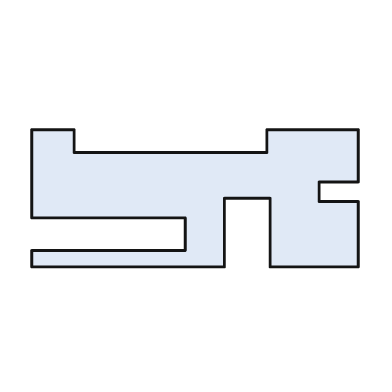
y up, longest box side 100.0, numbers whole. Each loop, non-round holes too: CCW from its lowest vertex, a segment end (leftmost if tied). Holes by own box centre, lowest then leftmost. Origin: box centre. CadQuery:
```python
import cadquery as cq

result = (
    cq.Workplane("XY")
    .moveTo(-50.0, -21.0)
    .lineTo(9.0, -21.0)
    .lineTo(9.0, 0.0)
    .lineTo(23.0, 0.0)
    .lineTo(23.0, -21.0)
    .lineTo(50.0, -21.0)
    .lineTo(50.0, -1.0)
    .lineTo(38.0, -1.0)
    .lineTo(38.0, 5.0)
    .lineTo(50.0, 5.0)
    .lineTo(50.0, 21.0)
    .lineTo(22.0, 21.0)
    .lineTo(22.0, 14.0)
    .lineTo(-37.0, 14.0)
    .lineTo(-37.0, 21.0)
    .lineTo(-50.0, 21.0)
    .lineTo(-50.0, -6.0)
    .lineTo(-3.0, -6.0)
    .lineTo(-3.0, -16.0)
    .lineTo(-50.0, -16.0)
    .close()
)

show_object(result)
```